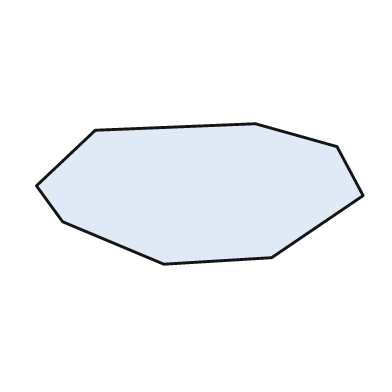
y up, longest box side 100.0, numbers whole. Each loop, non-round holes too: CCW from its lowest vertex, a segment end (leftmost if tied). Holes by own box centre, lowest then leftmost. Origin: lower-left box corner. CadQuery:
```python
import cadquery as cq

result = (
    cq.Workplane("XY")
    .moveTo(39.0, 0.0)
    .lineTo(72.0, 2.0)
    .lineTo(100.0, 21.0)
    .lineTo(92.0, 36.0)
    .lineTo(67.0, 43.0)
    .lineTo(18.0, 41.0)
    .lineTo(0.0, 24.0)
    .lineTo(8.0, 13.0)
    .close()
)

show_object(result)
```